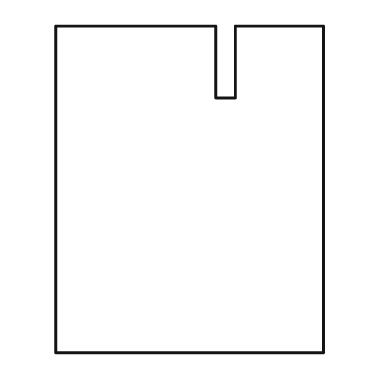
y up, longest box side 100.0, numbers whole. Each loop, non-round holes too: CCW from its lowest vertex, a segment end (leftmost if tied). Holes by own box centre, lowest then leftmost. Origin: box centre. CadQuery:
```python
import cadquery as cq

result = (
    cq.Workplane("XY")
    .moveTo(-41.0, -50.0)
    .lineTo(41.0, -50.0)
    .lineTo(41.0, 50.0)
    .lineTo(14.0, 50.0)
    .lineTo(14.0, 28.0)
    .lineTo(8.0, 28.0)
    .lineTo(8.0, 50.0)
    .lineTo(-41.0, 50.0)
    .close()
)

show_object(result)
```